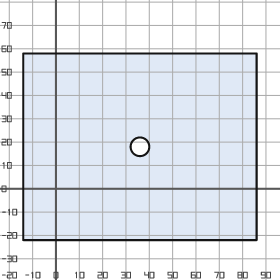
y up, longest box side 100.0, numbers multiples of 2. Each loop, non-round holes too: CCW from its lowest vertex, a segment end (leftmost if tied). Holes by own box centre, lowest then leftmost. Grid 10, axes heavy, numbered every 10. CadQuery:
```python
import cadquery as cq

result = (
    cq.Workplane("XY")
    .moveTo(-14.0, -22.0)
    .lineTo(86.0, -22.0)
    .lineTo(86.0, 58.0)
    .lineTo(-14.0, 58.0)
    .close()
    .moveTo(36.0, 18.0)
    .circle(4.0)
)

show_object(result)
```